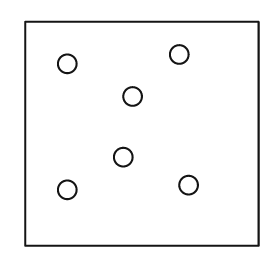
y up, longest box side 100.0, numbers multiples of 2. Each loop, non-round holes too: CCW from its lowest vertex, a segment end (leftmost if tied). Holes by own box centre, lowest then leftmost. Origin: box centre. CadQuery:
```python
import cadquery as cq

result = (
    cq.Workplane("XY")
    .moveTo(-50.0, -48.0)
    .lineTo(50.0, -48.0)
    .lineTo(50.0, 48.0)
    .lineTo(-50.0, 48.0)
    .close()
    .moveTo(-32.0, -24.0)
    .circle(4.0)
    .moveTo(20.0, -22.0)
    .circle(4.0)
    .moveTo(-8.0, -10.0)
    .circle(4.0)
    .moveTo(-4.0, 16.0)
    .circle(4.0)
    .moveTo(-32.0, 30.0)
    .circle(4.0)
    .moveTo(16.0, 34.0)
    .circle(4.0)
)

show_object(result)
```